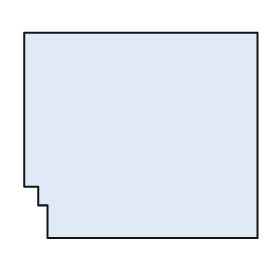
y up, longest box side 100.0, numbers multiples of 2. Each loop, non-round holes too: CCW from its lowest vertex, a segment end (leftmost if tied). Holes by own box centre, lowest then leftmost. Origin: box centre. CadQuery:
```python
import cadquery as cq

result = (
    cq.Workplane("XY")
    .moveTo(-40.0, -44.0)
    .lineTo(50.0, -44.0)
    .lineTo(50.0, 44.0)
    .lineTo(-50.0, 44.0)
    .lineTo(-50.0, -22.0)
    .lineTo(-44.0, -22.0)
    .lineTo(-44.0, -30.0)
    .lineTo(-40.0, -30.0)
    .close()
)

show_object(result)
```